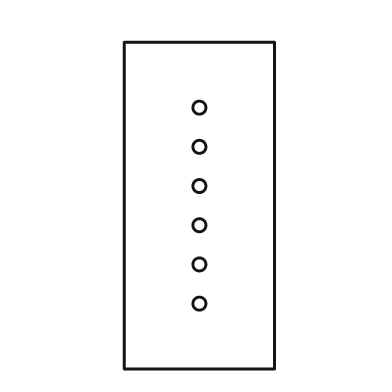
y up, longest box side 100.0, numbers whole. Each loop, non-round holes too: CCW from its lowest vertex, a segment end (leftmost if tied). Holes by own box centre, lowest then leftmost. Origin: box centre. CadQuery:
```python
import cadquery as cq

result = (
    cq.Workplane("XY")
    .moveTo(-23.0, -50.0)
    .lineTo(23.0, -50.0)
    .lineTo(23.0, 50.0)
    .lineTo(-23.0, 50.0)
    .close()
    .moveTo(0.0, -30.0)
    .circle(2.0)
    .moveTo(0.0, -18.0)
    .circle(2.0)
    .moveTo(0.0, -6.0)
    .circle(2.0)
    .moveTo(0.0, 6.0)
    .circle(2.0)
    .moveTo(0.0, 18.0)
    .circle(2.0)
    .moveTo(0.0, 30.0)
    .circle(2.0)
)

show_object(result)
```